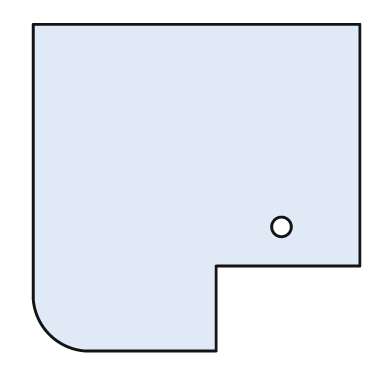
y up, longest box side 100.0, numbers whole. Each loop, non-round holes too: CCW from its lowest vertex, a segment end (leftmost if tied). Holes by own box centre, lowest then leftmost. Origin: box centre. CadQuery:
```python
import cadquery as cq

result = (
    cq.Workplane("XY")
    .moveTo(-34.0, -50.0)
    .lineTo(6.0, -50.0)
    .lineTo(6.0, -24.0)
    .lineTo(50.0, -24.0)
    .lineTo(50.0, 50.0)
    .lineTo(-50.0, 50.0)
    .lineTo(-50.0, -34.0)
    .threePointArc((-45.0, -45.0), (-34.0, -50.0))
    .close()
    .moveTo(26.0, -12.0)
    .circle(3.0)
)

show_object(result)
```